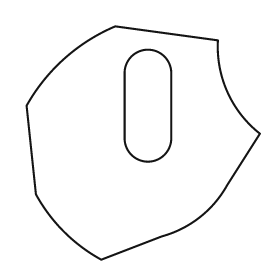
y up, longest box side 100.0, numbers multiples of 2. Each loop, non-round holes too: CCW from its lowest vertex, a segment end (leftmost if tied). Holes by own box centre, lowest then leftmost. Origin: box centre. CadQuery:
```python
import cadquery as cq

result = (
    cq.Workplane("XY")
    .moveTo(-18.0, -50.0)
    .lineTo(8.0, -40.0)
    .threePointArc((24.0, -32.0), (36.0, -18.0))
    .lineTo(50.0, 4.0)
    .threePointArc((36.0, 22.0), (32.0, 44.0))
    .lineTo(-12.0, 50.0)
    .threePointArc((-34.0, 36.0), (-50.0, 16.0))
    .lineTo(-46.0, -22.0)
    .threePointArc((-34.0, -38.0), (-18.0, -50.0))
    .close()
    .moveTo(-8.0, 2.0)
    .threePointArc((2.0, -8.0), (12.0, 2.0))
    .lineTo(12.0, 30.0)
    .threePointArc((2.0, 40.0), (-8.0, 30.0))
    .close()
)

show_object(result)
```